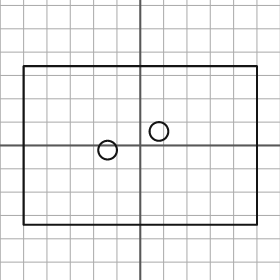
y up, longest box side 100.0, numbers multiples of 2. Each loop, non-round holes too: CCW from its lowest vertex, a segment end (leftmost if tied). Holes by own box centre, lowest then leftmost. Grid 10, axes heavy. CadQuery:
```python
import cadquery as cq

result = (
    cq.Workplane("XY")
    .moveTo(-50.0, -34.0)
    .lineTo(50.0, -34.0)
    .lineTo(50.0, 34.0)
    .lineTo(-50.0, 34.0)
    .close()
    .moveTo(-14.0, -2.0)
    .circle(4.0)
    .moveTo(8.0, 6.0)
    .circle(4.0)
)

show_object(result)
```